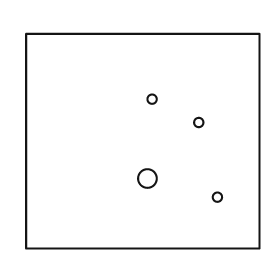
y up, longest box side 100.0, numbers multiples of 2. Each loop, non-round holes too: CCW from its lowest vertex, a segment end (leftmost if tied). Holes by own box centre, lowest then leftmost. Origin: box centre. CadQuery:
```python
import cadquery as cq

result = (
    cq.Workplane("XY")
    .moveTo(-50.0, -46.0)
    .lineTo(50.0, -46.0)
    .lineTo(50.0, 46.0)
    .lineTo(-50.0, 46.0)
    .close()
    .moveTo(32.0, -24.0)
    .circle(2.0)
    .moveTo(2.0, -16.0)
    .circle(4.0)
    .moveTo(24.0, 8.0)
    .circle(2.0)
    .moveTo(4.0, 18.0)
    .circle(2.0)
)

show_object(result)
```